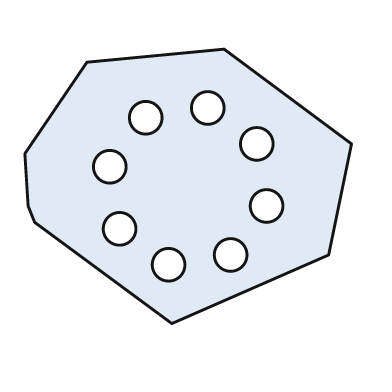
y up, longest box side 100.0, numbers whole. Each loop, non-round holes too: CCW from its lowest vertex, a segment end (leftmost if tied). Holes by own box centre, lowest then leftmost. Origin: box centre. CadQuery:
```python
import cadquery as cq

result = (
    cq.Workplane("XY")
    .moveTo(-5.0, -42.0)
    .lineTo(43.0, -21.0)
    .lineTo(50.0, 13.0)
    .lineTo(11.0, 42.0)
    .lineTo(-31.0, 38.0)
    .lineTo(-50.0, 10.0)
    .lineTo(-49.0, -6.0)
    .lineTo(-47.0, -11.0)
    .close()
    .moveTo(-6.0, -24.0)
    .circle(5.0)
    .moveTo(13.0, -21.0)
    .circle(5.0)
    .moveTo(-21.0, -13.0)
    .circle(5.0)
    .moveTo(24.0, -6.0)
    .circle(5.0)
    .moveTo(-24.0, 6.0)
    .circle(5.0)
    .moveTo(21.0, 13.0)
    .circle(5.0)
    .moveTo(-13.0, 21.0)
    .circle(5.0)
    .moveTo(6.0, 24.0)
    .circle(5.0)
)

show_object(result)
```